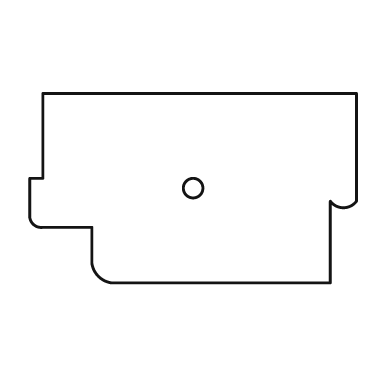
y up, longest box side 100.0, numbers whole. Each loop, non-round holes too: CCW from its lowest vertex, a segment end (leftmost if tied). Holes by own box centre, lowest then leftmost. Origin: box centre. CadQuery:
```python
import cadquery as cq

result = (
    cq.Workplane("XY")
    .moveTo(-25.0, -29.0)
    .lineTo(42.0, -29.0)
    .lineTo(42.0, -4.0)
    .threePointArc((46.0, -6.0), (50.0, -4.0))
    .lineTo(50.0, 29.0)
    .lineTo(-46.0, 29.0)
    .lineTo(-46.0, 3.0)
    .lineTo(-50.0, 3.0)
    .lineTo(-50.0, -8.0)
    .threePointArc((-49.0, -11.0), (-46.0, -12.0))
    .lineTo(-31.0, -12.0)
    .lineTo(-31.0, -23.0)
    .threePointArc((-29.0, -27.0), (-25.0, -29.0))
    .close()
    .moveTo(0.0, 0.0)
    .circle(3.0)
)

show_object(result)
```